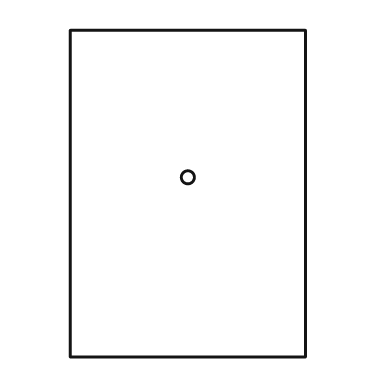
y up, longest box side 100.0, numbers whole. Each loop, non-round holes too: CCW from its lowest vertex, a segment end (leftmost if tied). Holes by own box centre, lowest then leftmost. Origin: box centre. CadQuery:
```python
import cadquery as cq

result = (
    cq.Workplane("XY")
    .moveTo(-36.0, -50.0)
    .lineTo(36.0, -50.0)
    .lineTo(36.0, 50.0)
    .lineTo(-36.0, 50.0)
    .close()
    .moveTo(0.0, 5.0)
    .circle(2.0)
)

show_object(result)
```